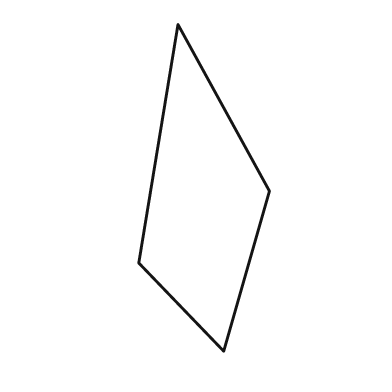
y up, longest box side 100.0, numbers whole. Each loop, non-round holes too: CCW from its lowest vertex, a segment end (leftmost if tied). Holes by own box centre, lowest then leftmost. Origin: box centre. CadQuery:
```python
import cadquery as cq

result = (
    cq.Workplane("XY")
    .moveTo(6.0, -50.0)
    .lineTo(20.0, -1.0)
    .lineTo(-8.0, 50.0)
    .lineTo(-20.0, -23.0)
    .close()
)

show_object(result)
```